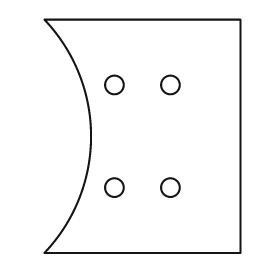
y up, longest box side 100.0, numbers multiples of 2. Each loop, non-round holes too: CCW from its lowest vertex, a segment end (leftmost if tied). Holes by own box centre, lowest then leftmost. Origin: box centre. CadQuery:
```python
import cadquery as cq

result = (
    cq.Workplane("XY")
    .moveTo(-42.0, -50.0)
    .lineTo(42.0, -50.0)
    .lineTo(42.0, 50.0)
    .lineTo(-42.0, 50.0)
    .threePointArc((-22.0, 0.0), (-42.0, -50.0))
    .close()
    .moveTo(-12.0, -22.0)
    .circle(4.0)
    .moveTo(12.0, -22.0)
    .circle(4.0)
    .moveTo(-12.0, 22.0)
    .circle(4.0)
    .moveTo(12.0, 22.0)
    .circle(4.0)
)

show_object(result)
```